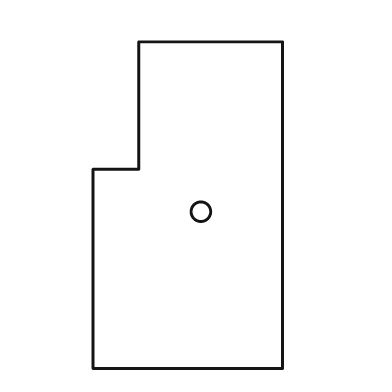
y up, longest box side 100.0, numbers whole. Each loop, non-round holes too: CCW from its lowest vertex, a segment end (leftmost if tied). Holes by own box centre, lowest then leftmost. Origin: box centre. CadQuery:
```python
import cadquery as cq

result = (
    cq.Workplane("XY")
    .moveTo(-29.0, -50.0)
    .lineTo(29.0, -50.0)
    .lineTo(29.0, 50.0)
    .lineTo(-15.0, 50.0)
    .lineTo(-15.0, 11.0)
    .lineTo(-29.0, 11.0)
    .close()
    .moveTo(4.0, -2.0)
    .circle(3.0)
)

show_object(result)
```